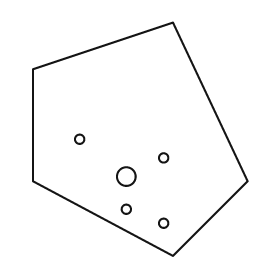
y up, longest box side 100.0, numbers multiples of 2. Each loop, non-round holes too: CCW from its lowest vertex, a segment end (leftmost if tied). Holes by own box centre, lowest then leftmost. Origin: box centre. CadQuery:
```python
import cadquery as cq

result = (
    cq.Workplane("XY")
    .moveTo(14.0, -50.0)
    .lineTo(46.0, -18.0)
    .lineTo(14.0, 50.0)
    .lineTo(-46.0, 30.0)
    .lineTo(-46.0, -18.0)
    .close()
    .moveTo(10.0, -36.0)
    .circle(2.0)
    .moveTo(-6.0, -30.0)
    .circle(2.0)
    .moveTo(-6.0, -16.0)
    .circle(4.0)
    .moveTo(10.0, -8.0)
    .circle(2.0)
    .moveTo(-26.0, 0.0)
    .circle(2.0)
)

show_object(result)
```